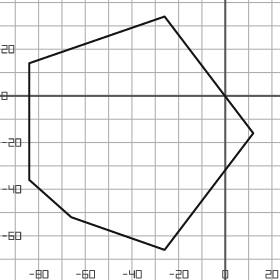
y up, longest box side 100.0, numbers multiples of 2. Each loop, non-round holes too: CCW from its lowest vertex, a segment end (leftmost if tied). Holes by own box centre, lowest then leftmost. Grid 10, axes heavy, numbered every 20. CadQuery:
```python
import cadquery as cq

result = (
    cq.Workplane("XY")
    .moveTo(-26.0, -66.0)
    .lineTo(12.0, -16.0)
    .lineTo(-26.0, 34.0)
    .lineTo(-84.0, 14.0)
    .lineTo(-84.0, -36.0)
    .lineTo(-66.0, -52.0)
    .close()
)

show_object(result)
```